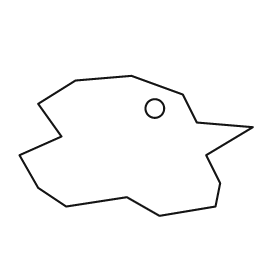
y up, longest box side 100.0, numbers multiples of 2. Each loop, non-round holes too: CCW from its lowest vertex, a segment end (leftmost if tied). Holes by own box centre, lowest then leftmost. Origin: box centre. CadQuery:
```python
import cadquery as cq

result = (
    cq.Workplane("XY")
    .moveTo(10.0, -30.0)
    .lineTo(34.0, -26.0)
    .lineTo(36.0, -16.0)
    .lineTo(30.0, -4.0)
    .lineTo(50.0, 8.0)
    .lineTo(26.0, 10.0)
    .lineTo(20.0, 22.0)
    .lineTo(-2.0, 30.0)
    .lineTo(-26.0, 28.0)
    .lineTo(-42.0, 18.0)
    .lineTo(-32.0, 4.0)
    .lineTo(-50.0, -4.0)
    .lineTo(-42.0, -18.0)
    .lineTo(-30.0, -26.0)
    .lineTo(-4.0, -22.0)
    .close()
    .moveTo(8.0, 16.0)
    .circle(4.0)
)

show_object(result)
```